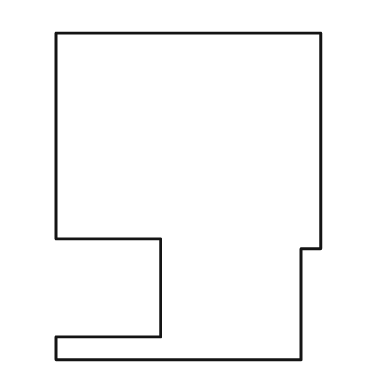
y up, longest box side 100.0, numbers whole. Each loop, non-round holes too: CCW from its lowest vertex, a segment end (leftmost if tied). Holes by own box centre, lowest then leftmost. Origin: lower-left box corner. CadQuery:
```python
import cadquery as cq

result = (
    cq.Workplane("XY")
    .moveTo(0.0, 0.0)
    .lineTo(75.0, 0.0)
    .lineTo(75.0, 34.0)
    .lineTo(81.0, 34.0)
    .lineTo(81.0, 100.0)
    .lineTo(0.0, 100.0)
    .lineTo(0.0, 37.0)
    .lineTo(32.0, 37.0)
    .lineTo(32.0, 7.0)
    .lineTo(0.0, 7.0)
    .close()
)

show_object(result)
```